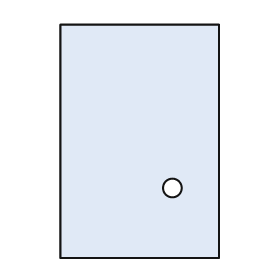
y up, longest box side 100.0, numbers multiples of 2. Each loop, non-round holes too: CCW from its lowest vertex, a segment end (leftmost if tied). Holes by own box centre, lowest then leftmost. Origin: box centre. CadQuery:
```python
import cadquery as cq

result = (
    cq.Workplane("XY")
    .moveTo(-34.0, -50.0)
    .lineTo(34.0, -50.0)
    .lineTo(34.0, 50.0)
    .lineTo(-34.0, 50.0)
    .close()
    .moveTo(14.0, -20.0)
    .circle(4.0)
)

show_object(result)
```